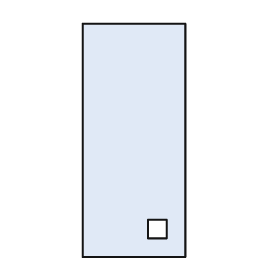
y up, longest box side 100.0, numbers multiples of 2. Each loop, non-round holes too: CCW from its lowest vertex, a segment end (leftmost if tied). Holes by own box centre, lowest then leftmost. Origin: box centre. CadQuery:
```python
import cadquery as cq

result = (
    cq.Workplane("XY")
    .moveTo(-22.0, -50.0)
    .lineTo(22.0, -50.0)
    .lineTo(22.0, 50.0)
    .lineTo(-22.0, 50.0)
    .close()
    .moveTo(6.0, -42.0)
    .lineTo(14.0, -42.0)
    .lineTo(14.0, -34.0)
    .lineTo(6.0, -34.0)
    .close()
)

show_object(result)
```